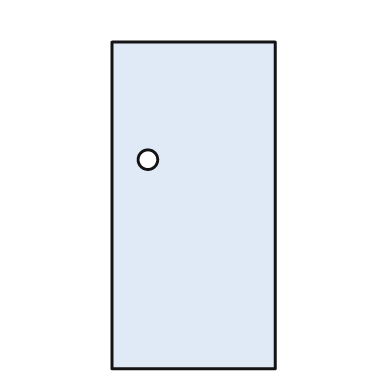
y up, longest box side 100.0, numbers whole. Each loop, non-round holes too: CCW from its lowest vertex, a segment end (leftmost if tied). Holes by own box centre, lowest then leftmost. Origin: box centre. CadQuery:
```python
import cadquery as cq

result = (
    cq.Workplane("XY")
    .moveTo(-25.0, -50.0)
    .lineTo(25.0, -50.0)
    .lineTo(25.0, 50.0)
    .lineTo(-25.0, 50.0)
    .close()
    .moveTo(-14.0, 14.0)
    .circle(3.0)
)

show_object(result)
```